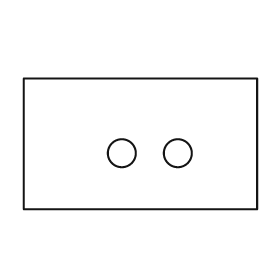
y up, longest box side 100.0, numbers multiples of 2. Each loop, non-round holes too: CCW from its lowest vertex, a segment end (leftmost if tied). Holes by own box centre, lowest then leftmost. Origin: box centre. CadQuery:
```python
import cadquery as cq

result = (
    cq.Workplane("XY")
    .moveTo(-50.0, -28.0)
    .lineTo(50.0, -28.0)
    .lineTo(50.0, 28.0)
    .lineTo(-50.0, 28.0)
    .close()
    .moveTo(-8.0, -4.0)
    .circle(6.0)
    .moveTo(16.0, -4.0)
    .circle(6.0)
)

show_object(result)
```